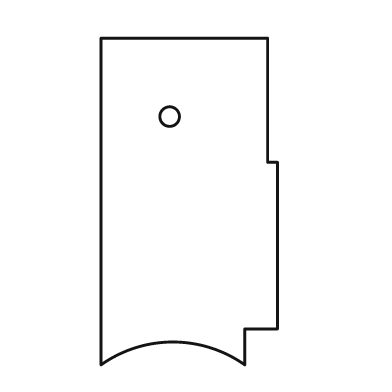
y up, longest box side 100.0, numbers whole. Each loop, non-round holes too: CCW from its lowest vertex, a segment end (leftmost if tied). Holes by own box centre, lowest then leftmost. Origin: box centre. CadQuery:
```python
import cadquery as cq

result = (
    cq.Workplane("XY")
    .moveTo(-27.0, -50.0)
    .threePointArc((-5.0, -43.0), (17.0, -50.0))
    .lineTo(17.0, -39.0)
    .lineTo(27.0, -39.0)
    .lineTo(27.0, 12.0)
    .lineTo(24.0, 12.0)
    .lineTo(24.0, 50.0)
    .lineTo(-27.0, 50.0)
    .close()
    .moveTo(-6.0, 26.0)
    .circle(3.0)
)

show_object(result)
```